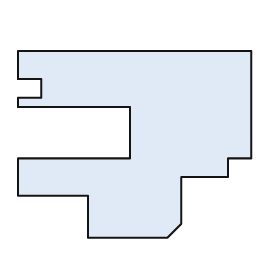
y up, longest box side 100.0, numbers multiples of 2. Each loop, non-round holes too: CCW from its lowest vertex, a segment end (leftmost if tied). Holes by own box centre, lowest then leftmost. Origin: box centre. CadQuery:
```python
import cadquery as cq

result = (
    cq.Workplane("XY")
    .moveTo(-20.0, -40.0)
    .lineTo(14.0, -40.0)
    .lineTo(20.0, -34.0)
    .lineTo(20.0, -14.0)
    .lineTo(40.0, -14.0)
    .lineTo(40.0, -6.0)
    .lineTo(50.0, -6.0)
    .lineTo(50.0, 40.0)
    .lineTo(-50.0, 40.0)
    .lineTo(-50.0, 28.0)
    .lineTo(-40.0, 28.0)
    .lineTo(-40.0, 20.0)
    .lineTo(-50.0, 20.0)
    .lineTo(-50.0, 16.0)
    .lineTo(-2.0, 16.0)
    .lineTo(-2.0, -6.0)
    .lineTo(-50.0, -6.0)
    .lineTo(-50.0, -22.0)
    .lineTo(-20.0, -22.0)
    .close()
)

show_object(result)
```